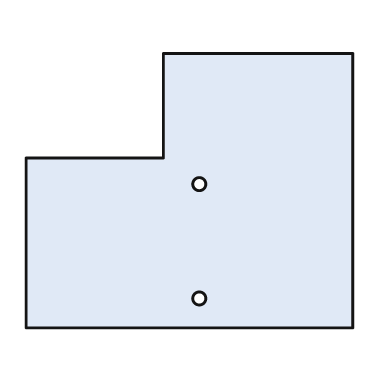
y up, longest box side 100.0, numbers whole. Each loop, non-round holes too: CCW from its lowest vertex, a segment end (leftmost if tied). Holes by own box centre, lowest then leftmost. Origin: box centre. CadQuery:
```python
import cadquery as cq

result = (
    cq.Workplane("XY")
    .moveTo(-50.0, -42.0)
    .lineTo(50.0, -42.0)
    .lineTo(50.0, 42.0)
    .lineTo(-8.0, 42.0)
    .lineTo(-8.0, 10.0)
    .lineTo(-50.0, 10.0)
    .close()
    .moveTo(3.0, -33.0)
    .circle(2.0)
    .moveTo(3.0, 2.0)
    .circle(2.0)
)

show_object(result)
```